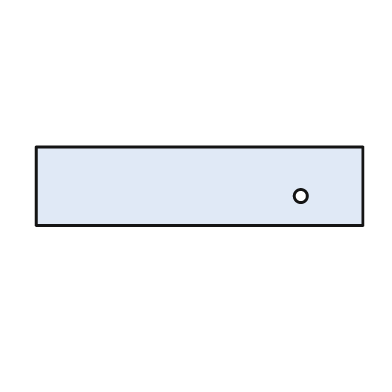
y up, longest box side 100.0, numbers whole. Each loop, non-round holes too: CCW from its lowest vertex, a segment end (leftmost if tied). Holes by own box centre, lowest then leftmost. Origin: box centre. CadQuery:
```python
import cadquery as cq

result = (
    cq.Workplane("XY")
    .moveTo(-50.0, -12.0)
    .lineTo(50.0, -12.0)
    .lineTo(50.0, 12.0)
    .lineTo(-50.0, 12.0)
    .close()
    .moveTo(31.0, -3.0)
    .circle(2.0)
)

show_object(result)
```